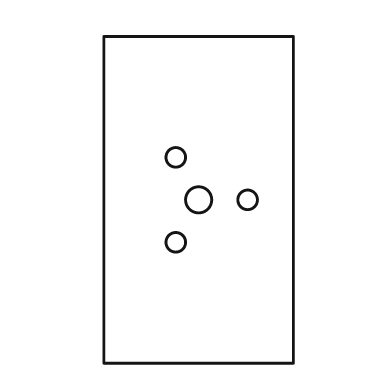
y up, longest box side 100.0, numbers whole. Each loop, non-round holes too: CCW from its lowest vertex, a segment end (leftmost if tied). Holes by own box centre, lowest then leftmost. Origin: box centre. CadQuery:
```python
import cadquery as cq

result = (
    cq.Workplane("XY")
    .moveTo(-29.0, -50.0)
    .lineTo(29.0, -50.0)
    .lineTo(29.0, 50.0)
    .lineTo(-29.0, 50.0)
    .close()
    .moveTo(-7.0, -13.0)
    .circle(3.0)
    .moveTo(0.0, 0.0)
    .circle(4.0)
    .moveTo(15.0, 0.0)
    .circle(3.0)
    .moveTo(-7.0, 13.0)
    .circle(3.0)
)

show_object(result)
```